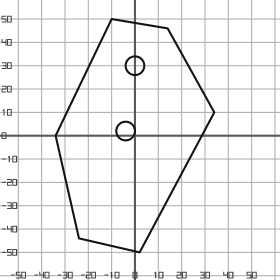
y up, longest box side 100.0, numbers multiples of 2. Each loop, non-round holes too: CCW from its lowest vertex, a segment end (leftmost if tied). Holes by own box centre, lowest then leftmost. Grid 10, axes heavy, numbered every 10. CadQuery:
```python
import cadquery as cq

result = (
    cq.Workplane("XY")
    .moveTo(2.0, -50.0)
    .lineTo(34.0, 10.0)
    .lineTo(14.0, 46.0)
    .lineTo(-10.0, 50.0)
    .lineTo(-34.0, 0.0)
    .lineTo(-24.0, -44.0)
    .close()
    .moveTo(-4.0, 2.0)
    .circle(4.0)
    .moveTo(0.0, 30.0)
    .circle(4.0)
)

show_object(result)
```